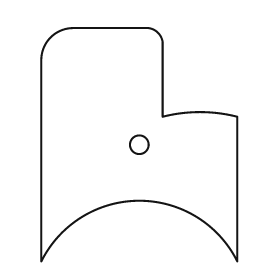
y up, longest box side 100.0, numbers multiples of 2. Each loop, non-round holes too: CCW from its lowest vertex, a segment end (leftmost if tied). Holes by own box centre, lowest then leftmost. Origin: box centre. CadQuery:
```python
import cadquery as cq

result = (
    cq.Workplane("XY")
    .moveTo(-42.0, -50.0)
    .threePointArc((0.0, -24.0), (42.0, -50.0))
    .lineTo(42.0, 12.0)
    .threePointArc((26.0, 14.0), (10.0, 12.0))
    .lineTo(10.0, 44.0)
    .threePointArc((8.0, 48.0), (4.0, 50.0))
    .lineTo(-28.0, 50.0)
    .threePointArc((-38.0, 46.0), (-42.0, 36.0))
    .close()
    .moveTo(0.0, 0.0)
    .circle(4.0)
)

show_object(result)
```